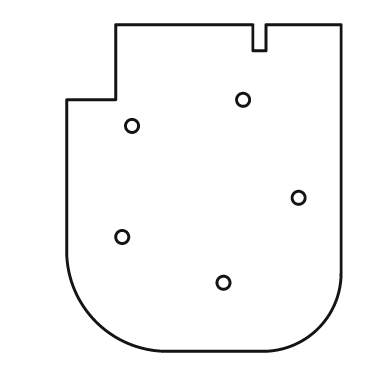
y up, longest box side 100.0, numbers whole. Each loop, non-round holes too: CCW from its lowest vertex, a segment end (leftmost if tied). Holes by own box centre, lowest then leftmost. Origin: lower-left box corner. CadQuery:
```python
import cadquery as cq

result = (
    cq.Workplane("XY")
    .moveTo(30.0, 0.0)
    .lineTo(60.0, 0.0)
    .threePointArc((77.0, 7.0), (84.0, 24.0))
    .lineTo(84.0, 100.0)
    .lineTo(61.0, 100.0)
    .lineTo(61.0, 92.0)
    .lineTo(57.0, 92.0)
    .lineTo(57.0, 100.0)
    .lineTo(15.0, 100.0)
    .lineTo(15.0, 77.0)
    .lineTo(0.0, 77.0)
    .lineTo(0.0, 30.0)
    .threePointArc((9.0, 9.0), (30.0, 0.0))
    .close()
    .moveTo(48.0, 21.0)
    .circle(2.0)
    .moveTo(17.0, 35.0)
    .circle(2.0)
    .moveTo(71.0, 47.0)
    .circle(2.0)
    .moveTo(20.0, 69.0)
    .circle(2.0)
    .moveTo(54.0, 77.0)
    .circle(2.0)
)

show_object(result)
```